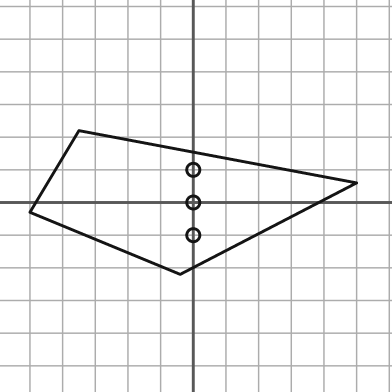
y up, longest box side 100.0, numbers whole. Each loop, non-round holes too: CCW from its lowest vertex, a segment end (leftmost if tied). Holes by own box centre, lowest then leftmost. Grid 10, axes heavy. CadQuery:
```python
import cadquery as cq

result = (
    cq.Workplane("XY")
    .moveTo(-4.0, -22.0)
    .lineTo(50.0, 6.0)
    .lineTo(-35.0, 22.0)
    .lineTo(-50.0, -3.0)
    .close()
    .moveTo(0.0, -10.0)
    .circle(2.0)
    .moveTo(0.0, 0.0)
    .circle(2.0)
    .moveTo(0.0, 10.0)
    .circle(2.0)
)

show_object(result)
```